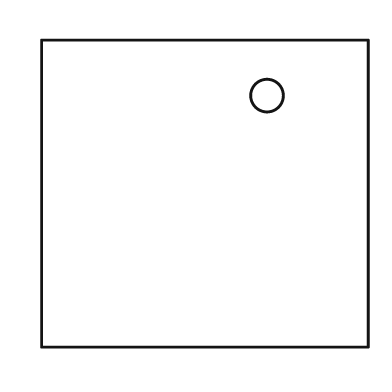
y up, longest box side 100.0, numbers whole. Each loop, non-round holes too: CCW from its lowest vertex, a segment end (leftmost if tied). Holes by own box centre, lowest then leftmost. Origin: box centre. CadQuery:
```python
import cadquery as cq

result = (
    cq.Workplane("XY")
    .moveTo(-50.0, -47.0)
    .lineTo(50.0, -47.0)
    .lineTo(50.0, 47.0)
    .lineTo(-50.0, 47.0)
    .close()
    .moveTo(19.0, 30.0)
    .circle(5.0)
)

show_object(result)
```